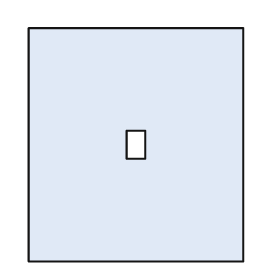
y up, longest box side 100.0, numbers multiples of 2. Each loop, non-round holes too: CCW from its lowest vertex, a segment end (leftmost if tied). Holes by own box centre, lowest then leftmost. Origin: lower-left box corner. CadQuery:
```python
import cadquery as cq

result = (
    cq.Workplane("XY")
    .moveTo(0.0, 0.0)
    .lineTo(92.0, 0.0)
    .lineTo(92.0, 100.0)
    .lineTo(0.0, 100.0)
    .close()
    .moveTo(42.0, 44.0)
    .lineTo(50.0, 44.0)
    .lineTo(50.0, 56.0)
    .lineTo(42.0, 56.0)
    .close()
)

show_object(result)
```